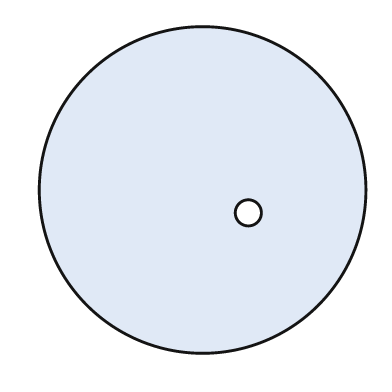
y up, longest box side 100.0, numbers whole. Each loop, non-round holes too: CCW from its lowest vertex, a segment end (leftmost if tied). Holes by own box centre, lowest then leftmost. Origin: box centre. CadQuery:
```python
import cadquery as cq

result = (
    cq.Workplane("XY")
    .moveTo(0.0, 0.0)
    .circle(50.0)
    .moveTo(14.0, -7.0)
    .circle(4.0)
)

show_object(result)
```